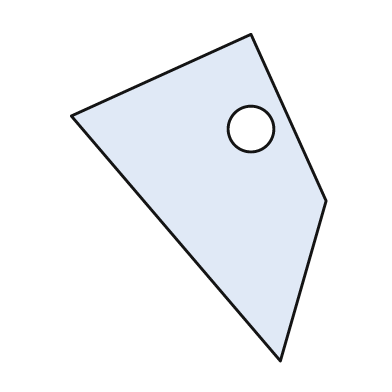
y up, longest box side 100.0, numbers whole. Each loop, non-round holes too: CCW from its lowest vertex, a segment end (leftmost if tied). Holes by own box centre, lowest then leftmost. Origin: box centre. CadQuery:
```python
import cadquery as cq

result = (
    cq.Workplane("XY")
    .moveTo(25.0, -50.0)
    .lineTo(39.0, -1.0)
    .lineTo(16.0, 50.0)
    .lineTo(-39.0, 25.0)
    .close()
    .moveTo(16.0, 21.0)
    .circle(7.0)
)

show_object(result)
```